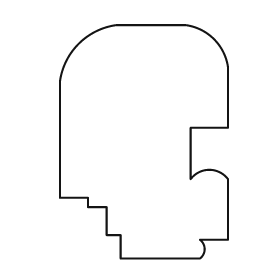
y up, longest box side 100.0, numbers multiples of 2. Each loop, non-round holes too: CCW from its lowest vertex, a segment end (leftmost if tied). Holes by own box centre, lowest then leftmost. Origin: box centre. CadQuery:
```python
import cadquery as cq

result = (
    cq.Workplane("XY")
    .moveTo(-10.0, -50.0)
    .lineTo(24.0, -50.0)
    .threePointArc((26.0, -46.0), (24.0, -42.0))
    .lineTo(36.0, -42.0)
    .lineTo(36.0, -16.0)
    .threePointArc((28.0, -12.0), (20.0, -16.0))
    .lineTo(20.0, 6.0)
    .lineTo(36.0, 6.0)
    .lineTo(36.0, 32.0)
    .threePointArc((30.0, 44.0), (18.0, 50.0))
    .lineTo(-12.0, 50.0)
    .threePointArc((-28.0, 42.0), (-36.0, 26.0))
    .lineTo(-36.0, -24.0)
    .lineTo(-24.0, -24.0)
    .lineTo(-24.0, -28.0)
    .lineTo(-16.0, -28.0)
    .lineTo(-16.0, -40.0)
    .lineTo(-10.0, -40.0)
    .close()
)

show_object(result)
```